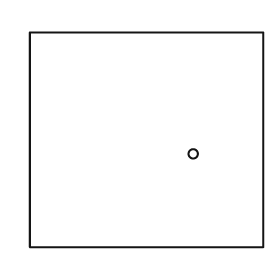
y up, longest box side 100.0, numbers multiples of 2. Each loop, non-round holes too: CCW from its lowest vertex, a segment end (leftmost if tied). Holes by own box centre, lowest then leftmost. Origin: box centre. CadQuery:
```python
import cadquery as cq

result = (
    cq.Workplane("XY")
    .moveTo(-50.0, -46.0)
    .lineTo(50.0, -46.0)
    .lineTo(50.0, 46.0)
    .lineTo(-50.0, 46.0)
    .close()
    .moveTo(20.0, -6.0)
    .circle(2.0)
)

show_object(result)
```